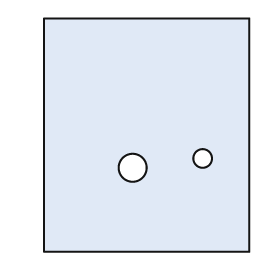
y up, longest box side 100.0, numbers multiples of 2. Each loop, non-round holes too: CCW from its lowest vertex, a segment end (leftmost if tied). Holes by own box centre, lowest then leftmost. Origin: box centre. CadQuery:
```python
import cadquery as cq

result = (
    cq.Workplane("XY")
    .moveTo(-44.0, -50.0)
    .lineTo(44.0, -50.0)
    .lineTo(44.0, 50.0)
    .lineTo(-44.0, 50.0)
    .close()
    .moveTo(-6.0, -14.0)
    .circle(6.0)
    .moveTo(24.0, -10.0)
    .circle(4.0)
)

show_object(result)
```